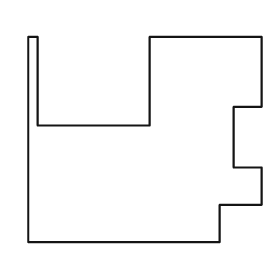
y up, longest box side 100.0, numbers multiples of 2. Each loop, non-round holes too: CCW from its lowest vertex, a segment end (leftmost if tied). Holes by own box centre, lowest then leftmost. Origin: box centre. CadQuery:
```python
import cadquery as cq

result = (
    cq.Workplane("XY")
    .moveTo(-50.0, -44.0)
    .lineTo(32.0, -44.0)
    .lineTo(32.0, -28.0)
    .lineTo(50.0, -28.0)
    .lineTo(50.0, -12.0)
    .lineTo(38.0, -12.0)
    .lineTo(38.0, 14.0)
    .lineTo(50.0, 14.0)
    .lineTo(50.0, 44.0)
    .lineTo(2.0, 44.0)
    .lineTo(2.0, 6.0)
    .lineTo(-46.0, 6.0)
    .lineTo(-46.0, 44.0)
    .lineTo(-50.0, 44.0)
    .close()
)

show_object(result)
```